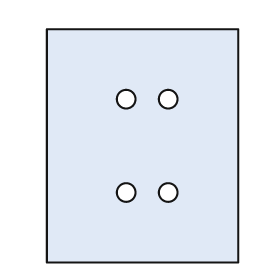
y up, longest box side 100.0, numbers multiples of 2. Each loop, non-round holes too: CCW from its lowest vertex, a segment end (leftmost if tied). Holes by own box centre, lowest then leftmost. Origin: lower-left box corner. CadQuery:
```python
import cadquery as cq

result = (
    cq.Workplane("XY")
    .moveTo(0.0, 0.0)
    .lineTo(82.0, 0.0)
    .lineTo(82.0, 100.0)
    .lineTo(0.0, 100.0)
    .close()
    .moveTo(34.0, 30.0)
    .circle(4.0)
    .moveTo(52.0, 30.0)
    .circle(4.0)
    .moveTo(34.0, 70.0)
    .circle(4.0)
    .moveTo(52.0, 70.0)
    .circle(4.0)
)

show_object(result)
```